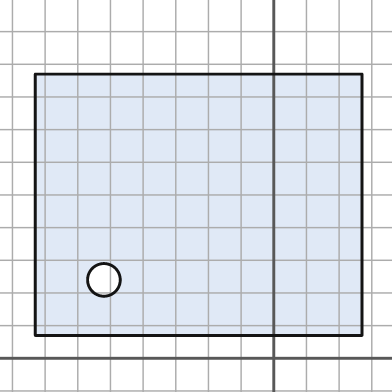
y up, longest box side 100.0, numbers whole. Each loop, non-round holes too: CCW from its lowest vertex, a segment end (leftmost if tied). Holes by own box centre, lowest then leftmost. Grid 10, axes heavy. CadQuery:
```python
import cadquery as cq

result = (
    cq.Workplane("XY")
    .moveTo(-73.0, 7.0)
    .lineTo(27.0, 7.0)
    .lineTo(27.0, 87.0)
    .lineTo(-73.0, 87.0)
    .close()
    .moveTo(-52.0, 24.0)
    .circle(5.0)
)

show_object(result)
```